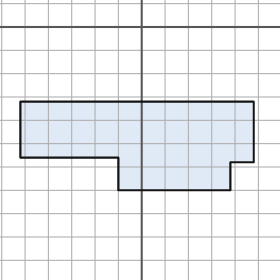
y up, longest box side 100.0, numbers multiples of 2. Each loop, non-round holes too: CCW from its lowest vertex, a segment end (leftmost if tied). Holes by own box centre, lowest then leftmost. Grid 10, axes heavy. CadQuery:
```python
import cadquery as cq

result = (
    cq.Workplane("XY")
    .moveTo(-10.0, -70.0)
    .lineTo(38.0, -70.0)
    .lineTo(38.0, -58.0)
    .lineTo(48.0, -58.0)
    .lineTo(48.0, -32.0)
    .lineTo(-52.0, -32.0)
    .lineTo(-52.0, -56.0)
    .lineTo(-10.0, -56.0)
    .close()
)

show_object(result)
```